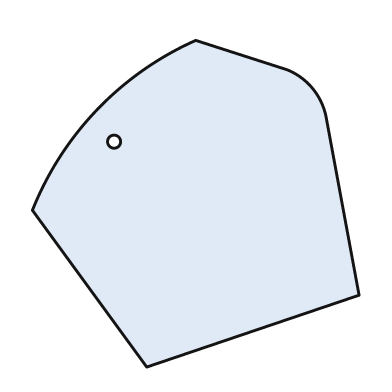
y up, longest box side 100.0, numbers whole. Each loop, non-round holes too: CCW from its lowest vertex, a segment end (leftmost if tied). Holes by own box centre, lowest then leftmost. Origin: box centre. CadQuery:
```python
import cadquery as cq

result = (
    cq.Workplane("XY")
    .moveTo(-15.0, -50.0)
    .lineTo(50.0, -28.0)
    .lineTo(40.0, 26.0)
    .threePointArc((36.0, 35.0), (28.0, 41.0))
    .lineTo(0.0, 50.0)
    .threePointArc((-30.0, 29.0), (-50.0, -2.0))
    .close()
    .moveTo(-25.0, 19.0)
    .circle(2.0)
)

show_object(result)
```